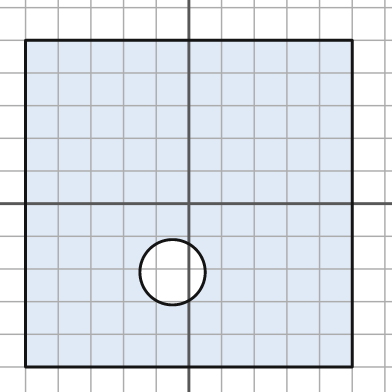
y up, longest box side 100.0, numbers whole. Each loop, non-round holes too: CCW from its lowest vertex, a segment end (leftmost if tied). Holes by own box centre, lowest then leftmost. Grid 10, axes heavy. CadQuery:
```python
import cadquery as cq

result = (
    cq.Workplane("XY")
    .moveTo(-50.0, -50.0)
    .lineTo(50.0, -50.0)
    .lineTo(50.0, 50.0)
    .lineTo(-50.0, 50.0)
    .close()
    .moveTo(-5.0, -21.0)
    .circle(10.0)
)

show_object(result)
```